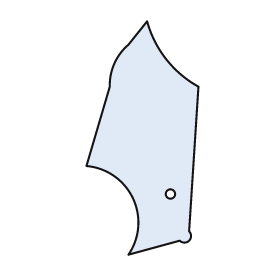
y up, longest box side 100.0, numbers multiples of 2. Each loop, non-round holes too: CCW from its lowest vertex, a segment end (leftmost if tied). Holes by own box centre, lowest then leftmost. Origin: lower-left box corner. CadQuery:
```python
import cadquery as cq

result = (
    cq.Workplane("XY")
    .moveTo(18.0, 0.0)
    .lineTo(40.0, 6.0)
    .threePointArc((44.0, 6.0), (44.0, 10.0))
    .lineTo(48.0, 72.0)
    .threePointArc((34.0, 84.0), (26.0, 100.0))
    .lineTo(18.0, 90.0)
    .threePointArc((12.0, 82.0), (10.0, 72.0))
    .lineTo(0.0, 38.0)
    .threePointArc((20.0, 24.0), (18.0, 0.0))
    .close()
    .moveTo(36.0, 26.0)
    .circle(2.0)
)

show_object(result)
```